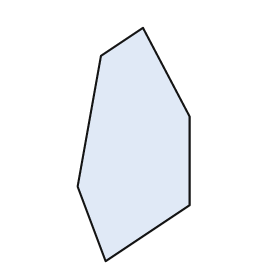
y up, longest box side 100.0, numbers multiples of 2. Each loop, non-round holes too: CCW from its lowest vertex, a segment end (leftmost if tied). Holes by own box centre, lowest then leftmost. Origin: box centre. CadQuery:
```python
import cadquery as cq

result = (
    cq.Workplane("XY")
    .moveTo(-12.0, -50.0)
    .lineTo(24.0, -26.0)
    .lineTo(24.0, 12.0)
    .lineTo(4.0, 50.0)
    .lineTo(-14.0, 38.0)
    .lineTo(-24.0, -18.0)
    .close()
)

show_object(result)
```